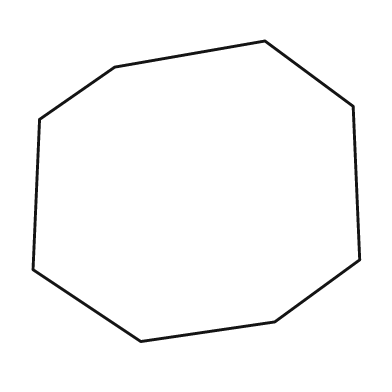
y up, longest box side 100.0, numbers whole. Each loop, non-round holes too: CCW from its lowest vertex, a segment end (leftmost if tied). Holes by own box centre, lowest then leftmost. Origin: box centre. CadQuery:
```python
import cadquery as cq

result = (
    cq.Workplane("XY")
    .moveTo(-17.0, -46.0)
    .lineTo(24.0, -40.0)
    .lineTo(50.0, -21.0)
    .lineTo(48.0, 26.0)
    .lineTo(21.0, 46.0)
    .lineTo(-25.0, 38.0)
    .lineTo(-48.0, 22.0)
    .lineTo(-50.0, -24.0)
    .close()
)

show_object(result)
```